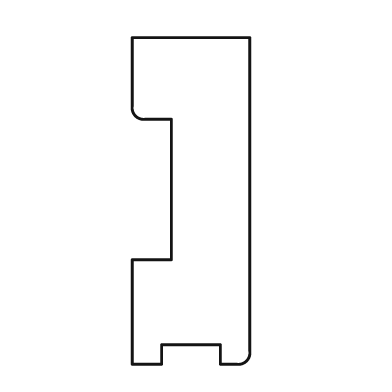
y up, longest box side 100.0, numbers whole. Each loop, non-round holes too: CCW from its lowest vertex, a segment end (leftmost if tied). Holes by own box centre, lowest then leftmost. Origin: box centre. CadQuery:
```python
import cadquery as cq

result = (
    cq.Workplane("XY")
    .moveTo(-18.0, -50.0)
    .lineTo(-9.0, -50.0)
    .lineTo(-9.0, -44.0)
    .lineTo(9.0, -44.0)
    .lineTo(9.0, -50.0)
    .lineTo(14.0, -50.0)
    .threePointArc((17.0, -49.0), (18.0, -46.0))
    .lineTo(18.0, 50.0)
    .lineTo(-18.0, 50.0)
    .lineTo(-18.0, 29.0)
    .threePointArc((-17.0, 26.0), (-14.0, 25.0))
    .lineTo(-6.0, 25.0)
    .lineTo(-6.0, -18.0)
    .lineTo(-18.0, -18.0)
    .close()
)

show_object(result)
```